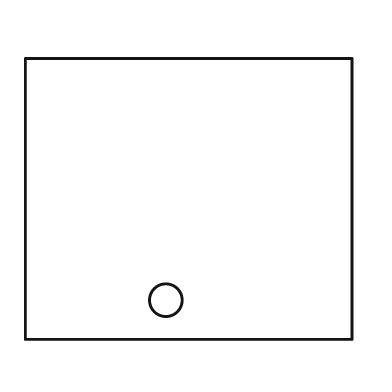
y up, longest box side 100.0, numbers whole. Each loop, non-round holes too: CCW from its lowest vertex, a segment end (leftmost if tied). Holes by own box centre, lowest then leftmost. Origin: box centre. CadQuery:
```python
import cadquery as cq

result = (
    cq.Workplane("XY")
    .moveTo(-50.0, -43.0)
    .lineTo(50.0, -43.0)
    .lineTo(50.0, 43.0)
    .lineTo(-50.0, 43.0)
    .close()
    .moveTo(-7.0, -31.0)
    .circle(5.0)
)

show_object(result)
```